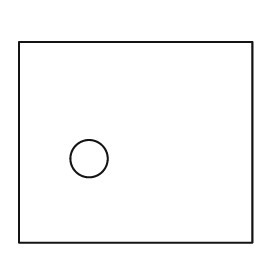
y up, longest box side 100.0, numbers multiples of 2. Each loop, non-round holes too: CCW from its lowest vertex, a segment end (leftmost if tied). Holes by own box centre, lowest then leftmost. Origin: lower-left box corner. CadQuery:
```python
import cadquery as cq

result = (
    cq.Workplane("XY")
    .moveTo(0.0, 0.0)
    .lineTo(100.0, 0.0)
    .lineTo(100.0, 86.0)
    .lineTo(0.0, 86.0)
    .close()
    .moveTo(30.0, 36.0)
    .circle(8.0)
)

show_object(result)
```